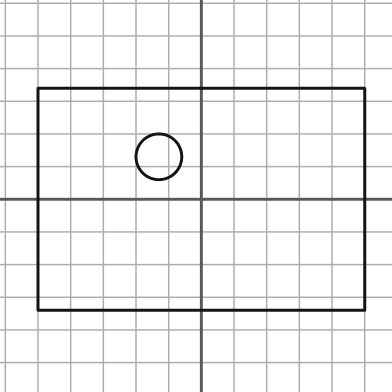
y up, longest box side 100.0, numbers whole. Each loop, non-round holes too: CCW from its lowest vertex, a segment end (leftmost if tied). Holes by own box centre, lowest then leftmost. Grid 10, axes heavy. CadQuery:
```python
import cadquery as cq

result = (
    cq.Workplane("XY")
    .moveTo(-50.0, -34.0)
    .lineTo(50.0, -34.0)
    .lineTo(50.0, 34.0)
    .lineTo(-50.0, 34.0)
    .close()
    .moveTo(-13.0, 13.0)
    .circle(7.0)
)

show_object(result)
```